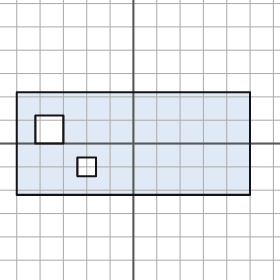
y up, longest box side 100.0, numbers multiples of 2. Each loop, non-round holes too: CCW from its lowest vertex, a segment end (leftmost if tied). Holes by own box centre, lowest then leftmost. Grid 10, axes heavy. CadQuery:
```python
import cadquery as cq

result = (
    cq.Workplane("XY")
    .moveTo(-50.0, -22.0)
    .lineTo(50.0, -22.0)
    .lineTo(50.0, 22.0)
    .lineTo(-50.0, 22.0)
    .close()
    .moveTo(-24.0, -14.0)
    .lineTo(-16.0, -14.0)
    .lineTo(-16.0, -6.0)
    .lineTo(-24.0, -6.0)
    .close()
    .moveTo(-42.0, 0.0)
    .lineTo(-30.0, 0.0)
    .lineTo(-30.0, 12.0)
    .lineTo(-42.0, 12.0)
    .close()
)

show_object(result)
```